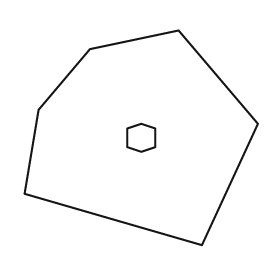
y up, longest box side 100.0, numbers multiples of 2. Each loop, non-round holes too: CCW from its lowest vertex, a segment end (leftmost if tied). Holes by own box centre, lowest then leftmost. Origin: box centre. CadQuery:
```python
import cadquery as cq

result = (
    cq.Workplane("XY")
    .moveTo(26.0, -46.0)
    .lineTo(50.0, 6.0)
    .lineTo(16.0, 46.0)
    .lineTo(-22.0, 38.0)
    .lineTo(-44.0, 12.0)
    .lineTo(-50.0, -24.0)
    .close()
    .moveTo(0.0, -6.0)
    .lineTo(6.0, -4.0)
    .lineTo(6.0, 4.0)
    .lineTo(0.0, 6.0)
    .lineTo(-6.0, 4.0)
    .lineTo(-6.0, -4.0)
    .close()
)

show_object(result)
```